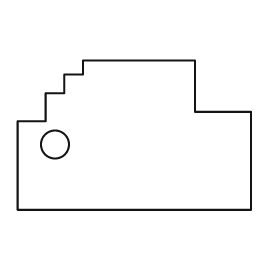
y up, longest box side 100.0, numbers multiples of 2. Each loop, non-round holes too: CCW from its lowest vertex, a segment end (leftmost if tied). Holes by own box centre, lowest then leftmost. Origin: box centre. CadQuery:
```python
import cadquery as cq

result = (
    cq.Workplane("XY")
    .moveTo(-50.0, -32.0)
    .lineTo(50.0, -32.0)
    .lineTo(50.0, 10.0)
    .lineTo(26.0, 10.0)
    .lineTo(26.0, 32.0)
    .lineTo(-22.0, 32.0)
    .lineTo(-22.0, 26.0)
    .lineTo(-30.0, 26.0)
    .lineTo(-30.0, 18.0)
    .lineTo(-38.0, 18.0)
    .lineTo(-38.0, 6.0)
    .lineTo(-50.0, 6.0)
    .close()
    .moveTo(-34.0, -4.0)
    .circle(6.0)
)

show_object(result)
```